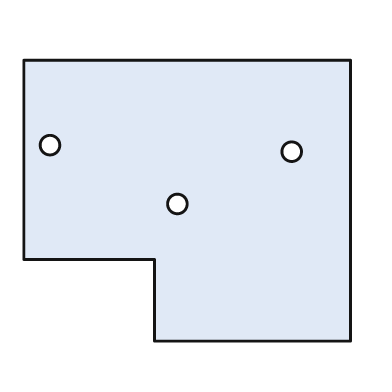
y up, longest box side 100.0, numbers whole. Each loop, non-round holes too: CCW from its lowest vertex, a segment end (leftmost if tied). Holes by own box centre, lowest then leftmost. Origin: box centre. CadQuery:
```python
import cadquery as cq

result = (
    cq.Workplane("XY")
    .moveTo(-10.0, -43.0)
    .lineTo(50.0, -43.0)
    .lineTo(50.0, 43.0)
    .lineTo(-50.0, 43.0)
    .lineTo(-50.0, -18.0)
    .lineTo(-10.0, -18.0)
    .close()
    .moveTo(-3.0, -1.0)
    .circle(3.0)
    .moveTo(32.0, 15.0)
    .circle(3.0)
    .moveTo(-42.0, 17.0)
    .circle(3.0)
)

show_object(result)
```